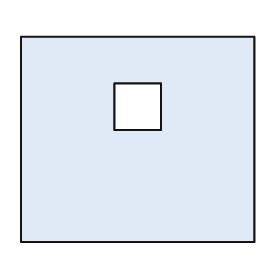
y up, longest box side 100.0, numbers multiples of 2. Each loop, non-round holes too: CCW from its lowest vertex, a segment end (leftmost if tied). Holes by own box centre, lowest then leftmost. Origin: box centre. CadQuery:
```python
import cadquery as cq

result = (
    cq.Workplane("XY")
    .moveTo(-50.0, -44.0)
    .lineTo(50.0, -44.0)
    .lineTo(50.0, 44.0)
    .lineTo(-50.0, 44.0)
    .close()
    .moveTo(-10.0, 4.0)
    .lineTo(10.0, 4.0)
    .lineTo(10.0, 24.0)
    .lineTo(-10.0, 24.0)
    .close()
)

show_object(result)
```